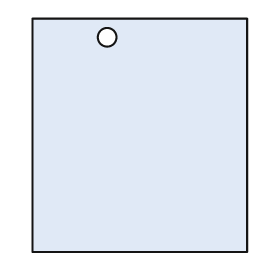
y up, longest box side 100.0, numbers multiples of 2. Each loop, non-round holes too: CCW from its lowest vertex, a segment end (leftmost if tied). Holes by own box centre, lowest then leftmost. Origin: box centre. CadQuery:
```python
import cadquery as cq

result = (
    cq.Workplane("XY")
    .moveTo(-46.0, -50.0)
    .lineTo(46.0, -50.0)
    .lineTo(46.0, 50.0)
    .lineTo(-46.0, 50.0)
    .close()
    .moveTo(-14.0, 42.0)
    .circle(4.0)
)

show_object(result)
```